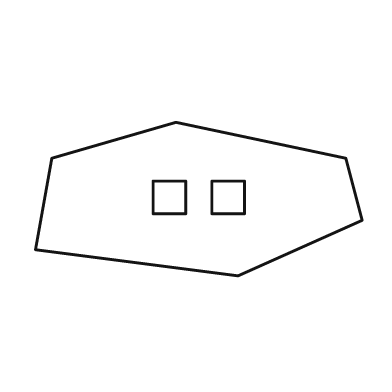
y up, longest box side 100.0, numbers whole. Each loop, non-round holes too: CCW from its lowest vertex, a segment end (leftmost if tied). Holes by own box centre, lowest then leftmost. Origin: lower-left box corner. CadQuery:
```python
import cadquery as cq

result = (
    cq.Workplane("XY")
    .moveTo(62.0, 0.0)
    .lineTo(100.0, 17.0)
    .lineTo(95.0, 36.0)
    .lineTo(43.0, 47.0)
    .lineTo(5.0, 36.0)
    .lineTo(0.0, 8.0)
    .close()
    .moveTo(36.0, 19.0)
    .lineTo(46.0, 19.0)
    .lineTo(46.0, 29.0)
    .lineTo(36.0, 29.0)
    .close()
    .moveTo(54.0, 19.0)
    .lineTo(64.0, 19.0)
    .lineTo(64.0, 29.0)
    .lineTo(54.0, 29.0)
    .close()
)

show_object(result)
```